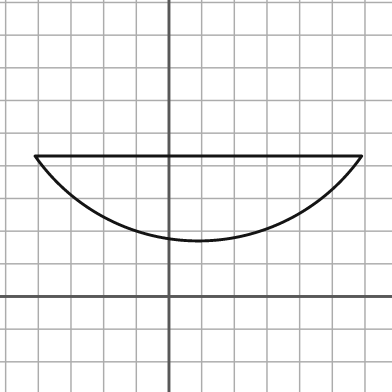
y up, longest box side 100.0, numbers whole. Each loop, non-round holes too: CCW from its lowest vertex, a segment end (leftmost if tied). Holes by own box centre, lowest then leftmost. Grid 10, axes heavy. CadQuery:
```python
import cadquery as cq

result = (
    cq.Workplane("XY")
    .moveTo(-41.0, 43.0)
    .threePointArc((9.0, 17.0), (59.0, 43.0))
    .close()
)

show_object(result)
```